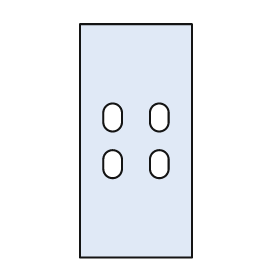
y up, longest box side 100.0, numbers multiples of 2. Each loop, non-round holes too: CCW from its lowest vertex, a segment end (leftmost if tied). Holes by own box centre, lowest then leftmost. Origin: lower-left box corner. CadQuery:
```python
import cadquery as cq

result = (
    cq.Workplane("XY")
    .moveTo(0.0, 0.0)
    .lineTo(48.0, 0.0)
    .lineTo(48.0, 100.0)
    .lineTo(0.0, 100.0)
    .close()
    .moveTo(10.0, 38.0)
    .threePointArc((14.0, 34.0), (18.0, 38.0))
    .lineTo(18.0, 42.0)
    .threePointArc((14.0, 46.0), (10.0, 42.0))
    .close()
    .moveTo(30.0, 38.0)
    .threePointArc((34.0, 34.0), (38.0, 38.0))
    .lineTo(38.0, 42.0)
    .threePointArc((34.0, 46.0), (30.0, 42.0))
    .close()
    .moveTo(10.0, 58.0)
    .threePointArc((14.0, 54.0), (18.0, 58.0))
    .lineTo(18.0, 62.0)
    .threePointArc((14.0, 66.0), (10.0, 62.0))
    .close()
    .moveTo(30.0, 58.0)
    .threePointArc((34.0, 54.0), (38.0, 58.0))
    .lineTo(38.0, 62.0)
    .threePointArc((34.0, 66.0), (30.0, 62.0))
    .close()
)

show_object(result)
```